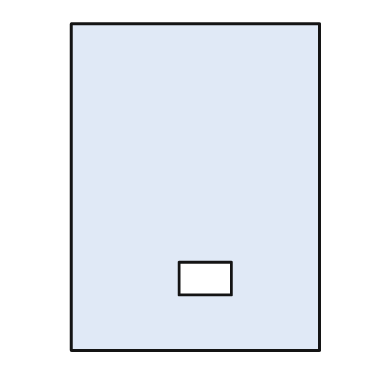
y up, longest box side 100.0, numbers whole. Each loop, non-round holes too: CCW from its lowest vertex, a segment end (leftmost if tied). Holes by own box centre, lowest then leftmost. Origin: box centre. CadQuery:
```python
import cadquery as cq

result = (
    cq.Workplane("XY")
    .moveTo(-38.0, -50.0)
    .lineTo(38.0, -50.0)
    .lineTo(38.0, 50.0)
    .lineTo(-38.0, 50.0)
    .close()
    .moveTo(-5.0, -33.0)
    .lineTo(11.0, -33.0)
    .lineTo(11.0, -23.0)
    .lineTo(-5.0, -23.0)
    .close()
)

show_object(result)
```